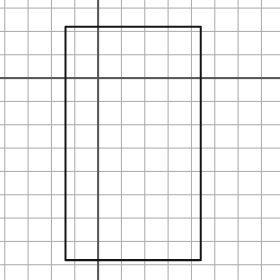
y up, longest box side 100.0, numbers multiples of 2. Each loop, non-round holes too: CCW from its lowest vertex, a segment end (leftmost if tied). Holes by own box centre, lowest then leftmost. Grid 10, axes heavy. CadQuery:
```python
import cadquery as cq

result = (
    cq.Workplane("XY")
    .moveTo(-14.0, -78.0)
    .lineTo(44.0, -78.0)
    .lineTo(44.0, 22.0)
    .lineTo(-14.0, 22.0)
    .close()
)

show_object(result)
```